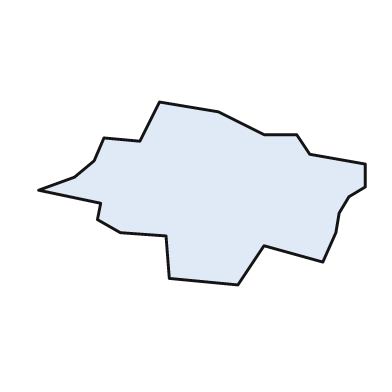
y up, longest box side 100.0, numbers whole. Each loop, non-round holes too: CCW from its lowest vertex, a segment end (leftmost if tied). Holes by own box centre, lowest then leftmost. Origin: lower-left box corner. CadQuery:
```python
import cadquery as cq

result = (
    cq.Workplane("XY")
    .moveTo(61.0, 0.0)
    .lineTo(69.0, 12.0)
    .lineTo(87.0, 7.0)
    .lineTo(91.0, 16.0)
    .lineTo(92.0, 22.0)
    .lineTo(95.0, 27.0)
    .lineTo(100.0, 30.0)
    .lineTo(100.0, 37.0)
    .lineTo(83.0, 40.0)
    .lineTo(79.0, 46.0)
    .lineTo(69.0, 46.0)
    .lineTo(55.0, 53.0)
    .lineTo(37.0, 56.0)
    .lineTo(31.0, 44.0)
    .lineTo(20.0, 45.0)
    .lineTo(17.0, 38.0)
    .lineTo(11.0, 33.0)
    .lineTo(0.0, 29.0)
    .lineTo(19.0, 25.0)
    .lineTo(18.0, 20.0)
    .lineTo(25.0, 16.0)
    .lineTo(39.0, 15.0)
    .lineTo(40.0, 2.0)
    .close()
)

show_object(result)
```